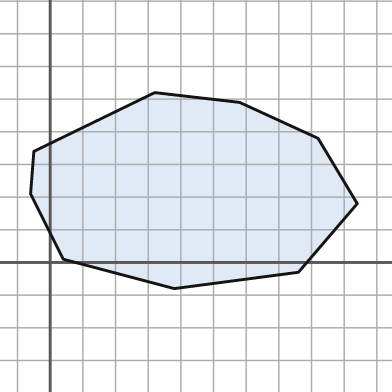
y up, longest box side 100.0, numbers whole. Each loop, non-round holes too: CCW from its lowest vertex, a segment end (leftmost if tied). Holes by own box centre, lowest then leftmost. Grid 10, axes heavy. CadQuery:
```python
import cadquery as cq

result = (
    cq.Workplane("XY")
    .moveTo(38.0, -8.0)
    .lineTo(76.0, -3.0)
    .lineTo(94.0, 18.0)
    .lineTo(82.0, 38.0)
    .lineTo(58.0, 49.0)
    .lineTo(32.0, 52.0)
    .lineTo(-5.0, 34.0)
    .lineTo(-6.0, 21.0)
    .lineTo(4.0, 1.0)
    .close()
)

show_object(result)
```